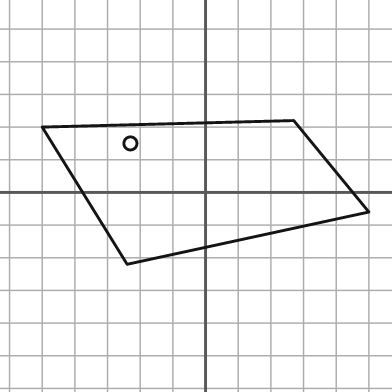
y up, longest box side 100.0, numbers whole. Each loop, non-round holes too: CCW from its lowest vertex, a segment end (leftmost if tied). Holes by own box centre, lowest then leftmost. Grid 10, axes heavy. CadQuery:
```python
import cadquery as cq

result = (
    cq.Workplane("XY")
    .moveTo(-24.0, -22.0)
    .lineTo(50.0, -6.0)
    .lineTo(27.0, 22.0)
    .lineTo(-50.0, 20.0)
    .close()
    .moveTo(-23.0, 15.0)
    .circle(2.0)
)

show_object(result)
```